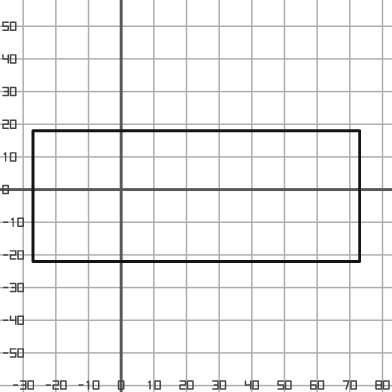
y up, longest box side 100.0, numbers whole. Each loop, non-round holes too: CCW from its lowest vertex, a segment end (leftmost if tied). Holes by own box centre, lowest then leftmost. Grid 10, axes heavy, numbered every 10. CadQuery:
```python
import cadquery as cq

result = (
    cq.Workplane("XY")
    .moveTo(-27.0, -22.0)
    .lineTo(73.0, -22.0)
    .lineTo(73.0, 18.0)
    .lineTo(-27.0, 18.0)
    .close()
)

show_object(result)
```